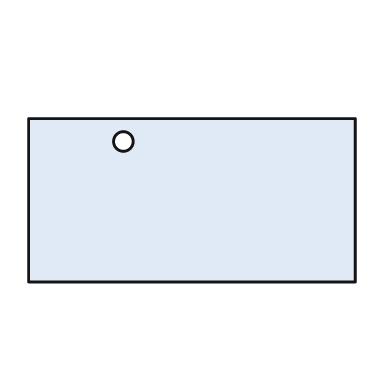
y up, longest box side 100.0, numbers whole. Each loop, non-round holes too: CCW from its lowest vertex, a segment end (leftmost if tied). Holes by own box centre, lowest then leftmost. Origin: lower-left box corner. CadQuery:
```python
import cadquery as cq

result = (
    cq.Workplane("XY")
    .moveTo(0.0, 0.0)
    .lineTo(100.0, 0.0)
    .lineTo(100.0, 50.0)
    .lineTo(0.0, 50.0)
    .close()
    .moveTo(29.0, 43.0)
    .circle(3.0)
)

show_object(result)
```